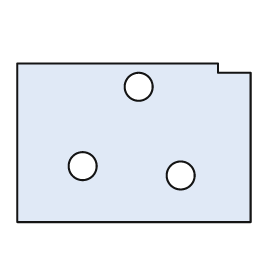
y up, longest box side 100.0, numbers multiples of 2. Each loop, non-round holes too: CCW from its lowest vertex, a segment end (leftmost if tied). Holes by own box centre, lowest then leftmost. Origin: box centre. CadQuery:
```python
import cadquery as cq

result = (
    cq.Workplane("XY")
    .moveTo(-50.0, -34.0)
    .lineTo(50.0, -34.0)
    .lineTo(50.0, 30.0)
    .lineTo(36.0, 30.0)
    .lineTo(36.0, 34.0)
    .lineTo(-50.0, 34.0)
    .close()
    .moveTo(20.0, -14.0)
    .circle(6.0)
    .moveTo(-22.0, -10.0)
    .circle(6.0)
    .moveTo(2.0, 24.0)
    .circle(6.0)
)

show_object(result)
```